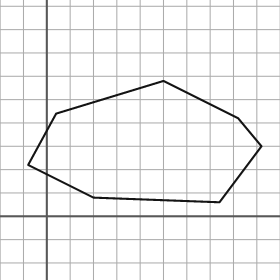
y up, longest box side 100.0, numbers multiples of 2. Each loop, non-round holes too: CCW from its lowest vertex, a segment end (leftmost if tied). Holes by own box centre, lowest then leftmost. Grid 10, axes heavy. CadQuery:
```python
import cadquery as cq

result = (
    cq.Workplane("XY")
    .moveTo(74.0, 6.0)
    .lineTo(92.0, 30.0)
    .lineTo(82.0, 42.0)
    .lineTo(50.0, 58.0)
    .lineTo(4.0, 44.0)
    .lineTo(-8.0, 22.0)
    .lineTo(20.0, 8.0)
    .close()
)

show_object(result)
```